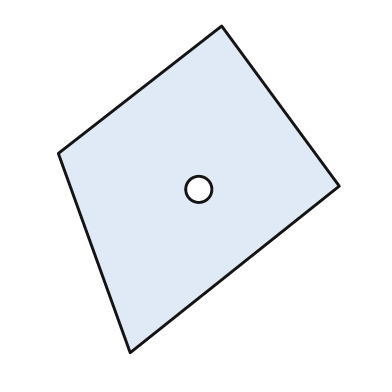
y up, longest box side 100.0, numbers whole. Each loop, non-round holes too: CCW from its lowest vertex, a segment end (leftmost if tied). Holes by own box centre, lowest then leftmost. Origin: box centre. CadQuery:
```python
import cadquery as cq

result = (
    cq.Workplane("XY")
    .moveTo(-21.0, -50.0)
    .lineTo(43.0, 1.0)
    .lineTo(7.0, 50.0)
    .lineTo(-43.0, 11.0)
    .close()
    .moveTo(0.0, 0.0)
    .circle(4.0)
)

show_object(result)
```